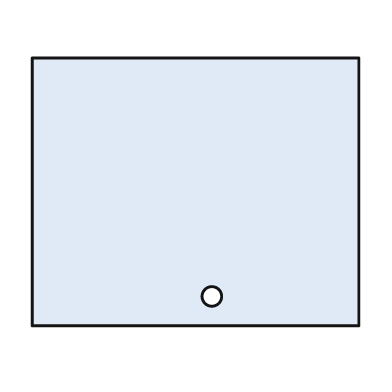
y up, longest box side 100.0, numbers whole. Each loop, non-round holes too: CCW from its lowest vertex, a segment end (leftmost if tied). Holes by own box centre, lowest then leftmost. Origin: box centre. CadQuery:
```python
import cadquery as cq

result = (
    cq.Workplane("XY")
    .moveTo(-50.0, -41.0)
    .lineTo(50.0, -41.0)
    .lineTo(50.0, 41.0)
    .lineTo(-50.0, 41.0)
    .close()
    .moveTo(5.0, -32.0)
    .circle(3.0)
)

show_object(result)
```